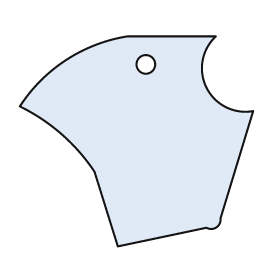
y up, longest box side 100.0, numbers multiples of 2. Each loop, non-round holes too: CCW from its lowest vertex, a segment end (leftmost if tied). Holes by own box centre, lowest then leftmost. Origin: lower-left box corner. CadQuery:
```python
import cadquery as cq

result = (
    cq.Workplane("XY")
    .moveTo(42.0, 0.0)
    .lineTo(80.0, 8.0)
    .threePointArc((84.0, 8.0), (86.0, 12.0))
    .lineTo(100.0, 58.0)
    .threePointArc((80.0, 68.0), (84.0, 90.0))
    .lineTo(46.0, 90.0)
    .threePointArc((20.0, 80.0), (0.0, 60.0))
    .threePointArc((18.0, 48.0), (32.0, 32.0))
    .close()
    .moveTo(54.0, 78.0)
    .circle(4.0)
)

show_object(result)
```